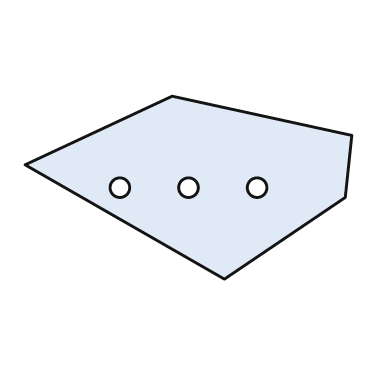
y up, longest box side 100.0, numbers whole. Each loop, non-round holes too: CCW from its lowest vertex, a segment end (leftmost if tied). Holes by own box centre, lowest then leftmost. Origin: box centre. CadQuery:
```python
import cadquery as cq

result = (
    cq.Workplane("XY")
    .moveTo(11.0, -28.0)
    .lineTo(48.0, -3.0)
    .lineTo(50.0, 16.0)
    .lineTo(-5.0, 28.0)
    .lineTo(-50.0, 7.0)
    .close()
    .moveTo(-21.0, 0.0)
    .circle(3.0)
    .moveTo(0.0, 0.0)
    .circle(3.0)
    .moveTo(21.0, 0.0)
    .circle(3.0)
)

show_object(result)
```